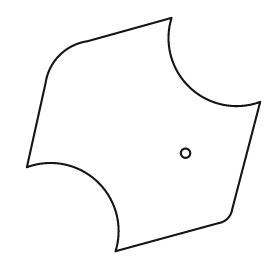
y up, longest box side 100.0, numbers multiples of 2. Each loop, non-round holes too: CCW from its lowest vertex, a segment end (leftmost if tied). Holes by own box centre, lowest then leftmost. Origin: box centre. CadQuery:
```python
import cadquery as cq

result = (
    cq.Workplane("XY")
    .moveTo(-12.0, -50.0)
    .lineTo(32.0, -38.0)
    .threePointArc((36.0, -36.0), (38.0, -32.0))
    .lineTo(50.0, 14.0)
    .threePointArc((20.0, 20.0), (12.0, 50.0))
    .lineTo(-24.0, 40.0)
    .threePointArc((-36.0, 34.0), (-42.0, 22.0))
    .lineTo(-50.0, -14.0)
    .threePointArc((-20.0, -20.0), (-12.0, -50.0))
    .close()
    .moveTo(18.0, -8.0)
    .circle(2.0)
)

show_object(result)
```